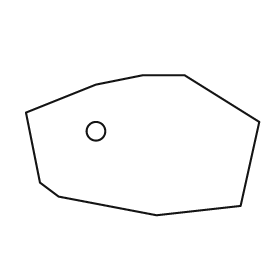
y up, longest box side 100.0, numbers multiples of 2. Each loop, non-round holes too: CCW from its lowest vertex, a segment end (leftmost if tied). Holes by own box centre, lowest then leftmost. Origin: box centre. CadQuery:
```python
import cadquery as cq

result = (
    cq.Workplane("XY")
    .moveTo(6.0, -30.0)
    .lineTo(42.0, -26.0)
    .lineTo(50.0, 10.0)
    .lineTo(18.0, 30.0)
    .lineTo(0.0, 30.0)
    .lineTo(-20.0, 26.0)
    .lineTo(-50.0, 14.0)
    .lineTo(-44.0, -16.0)
    .lineTo(-36.0, -22.0)
    .close()
    .moveTo(-20.0, 6.0)
    .circle(4.0)
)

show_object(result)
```